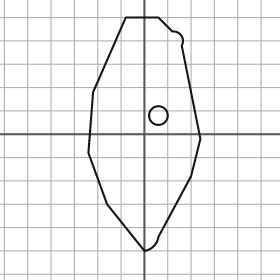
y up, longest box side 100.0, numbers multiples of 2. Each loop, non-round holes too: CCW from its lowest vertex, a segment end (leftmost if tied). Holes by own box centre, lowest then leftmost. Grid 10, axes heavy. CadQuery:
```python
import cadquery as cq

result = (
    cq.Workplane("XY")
    .moveTo(0.0, -50.0)
    .threePointArc((4.0, -48.0), (6.0, -44.0))
    .lineTo(20.0, -18.0)
    .lineTo(24.0, -2.0)
    .lineTo(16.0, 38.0)
    .threePointArc((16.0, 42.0), (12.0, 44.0))
    .lineTo(6.0, 50.0)
    .lineTo(-8.0, 50.0)
    .lineTo(-22.0, 18.0)
    .lineTo(-24.0, -8.0)
    .lineTo(-16.0, -30.0)
    .close()
    .moveTo(6.0, 8.0)
    .circle(4.0)
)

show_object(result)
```